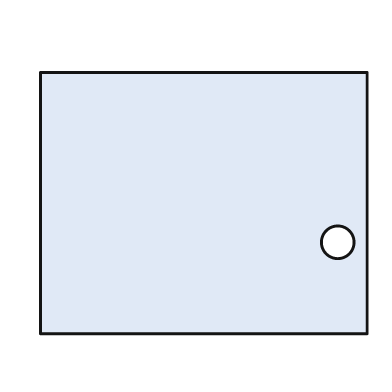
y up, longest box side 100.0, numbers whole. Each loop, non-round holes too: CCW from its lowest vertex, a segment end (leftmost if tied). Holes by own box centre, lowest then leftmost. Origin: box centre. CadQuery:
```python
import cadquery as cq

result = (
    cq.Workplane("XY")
    .moveTo(-50.0, -40.0)
    .lineTo(50.0, -40.0)
    .lineTo(50.0, 40.0)
    .lineTo(-50.0, 40.0)
    .close()
    .moveTo(41.0, -12.0)
    .circle(5.0)
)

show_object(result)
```